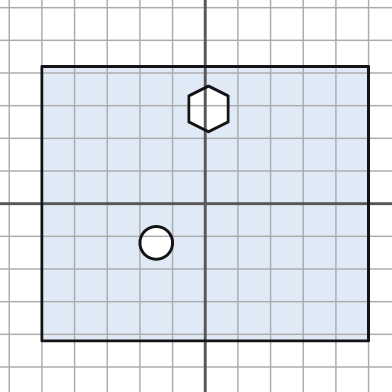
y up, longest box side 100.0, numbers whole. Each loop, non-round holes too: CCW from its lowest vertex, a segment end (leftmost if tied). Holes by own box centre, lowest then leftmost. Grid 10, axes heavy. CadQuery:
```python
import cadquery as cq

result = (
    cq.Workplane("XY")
    .moveTo(-50.0, -42.0)
    .lineTo(50.0, -42.0)
    .lineTo(50.0, 42.0)
    .lineTo(-50.0, 42.0)
    .close()
    .moveTo(-15.0, -12.0)
    .circle(5.0)
    .moveTo(1.0, 22.0)
    .lineTo(7.0, 25.0)
    .lineTo(7.0, 33.0)
    .lineTo(1.0, 36.0)
    .lineTo(-5.0, 33.0)
    .lineTo(-5.0, 25.0)
    .close()
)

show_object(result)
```